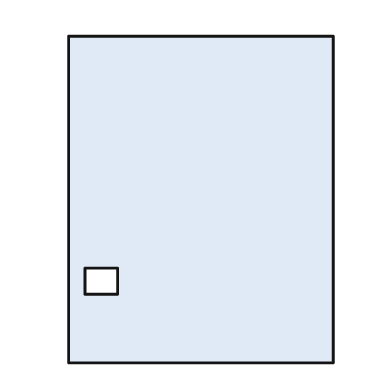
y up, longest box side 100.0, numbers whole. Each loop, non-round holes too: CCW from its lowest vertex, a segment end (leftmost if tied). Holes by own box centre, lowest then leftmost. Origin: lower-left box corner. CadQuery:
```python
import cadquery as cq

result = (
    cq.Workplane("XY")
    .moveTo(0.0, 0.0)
    .lineTo(81.0, 0.0)
    .lineTo(81.0, 100.0)
    .lineTo(0.0, 100.0)
    .close()
    .moveTo(5.0, 21.0)
    .lineTo(15.0, 21.0)
    .lineTo(15.0, 29.0)
    .lineTo(5.0, 29.0)
    .close()
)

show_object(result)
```